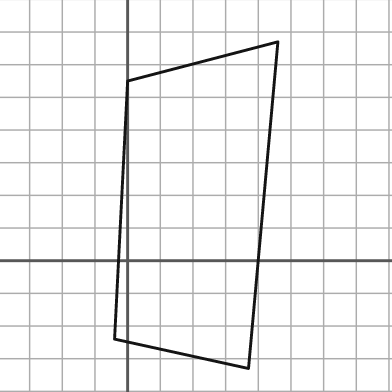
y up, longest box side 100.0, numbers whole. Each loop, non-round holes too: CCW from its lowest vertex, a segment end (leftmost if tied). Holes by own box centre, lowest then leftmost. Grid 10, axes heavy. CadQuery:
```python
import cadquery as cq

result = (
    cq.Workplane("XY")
    .moveTo(37.0, -33.0)
    .lineTo(46.0, 67.0)
    .lineTo(0.0, 55.0)
    .lineTo(-4.0, -24.0)
    .close()
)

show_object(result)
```